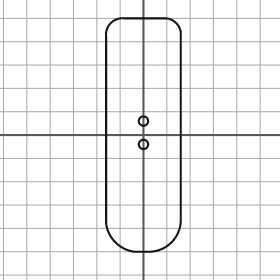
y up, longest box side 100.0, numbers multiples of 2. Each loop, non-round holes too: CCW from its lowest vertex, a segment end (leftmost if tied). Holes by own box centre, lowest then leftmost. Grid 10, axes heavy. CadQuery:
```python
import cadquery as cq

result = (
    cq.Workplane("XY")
    .moveTo(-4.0, -50.0)
    .lineTo(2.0, -50.0)
    .threePointArc((12.0, -46.0), (16.0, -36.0))
    .lineTo(16.0, 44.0)
    .threePointArc((14.0, 48.0), (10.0, 50.0))
    .lineTo(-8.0, 50.0)
    .threePointArc((-14.0, 48.0), (-16.0, 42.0))
    .lineTo(-16.0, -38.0)
    .threePointArc((-12.0, -46.0), (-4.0, -50.0))
    .close()
    .moveTo(0.0, -4.0)
    .circle(2.0)
    .moveTo(0.0, 6.0)
    .circle(2.0)
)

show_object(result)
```